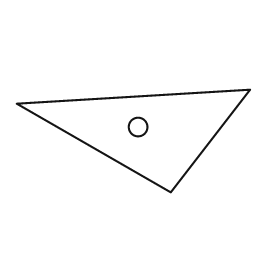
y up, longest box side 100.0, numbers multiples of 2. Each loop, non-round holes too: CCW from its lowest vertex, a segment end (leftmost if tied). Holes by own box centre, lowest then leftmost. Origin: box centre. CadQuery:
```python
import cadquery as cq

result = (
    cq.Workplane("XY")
    .moveTo(16.0, -22.0)
    .lineTo(50.0, 22.0)
    .lineTo(-50.0, 16.0)
    .close()
    .moveTo(2.0, 6.0)
    .circle(4.0)
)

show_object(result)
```